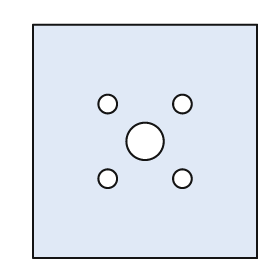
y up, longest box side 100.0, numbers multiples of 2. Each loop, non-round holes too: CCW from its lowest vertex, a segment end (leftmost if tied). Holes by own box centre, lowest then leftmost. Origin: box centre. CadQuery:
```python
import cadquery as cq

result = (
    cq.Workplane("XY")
    .moveTo(-48.0, -50.0)
    .lineTo(48.0, -50.0)
    .lineTo(48.0, 50.0)
    .lineTo(-48.0, 50.0)
    .close()
    .moveTo(-16.0, -16.0)
    .circle(4.0)
    .moveTo(16.0, -16.0)
    .circle(4.0)
    .moveTo(0.0, 0.0)
    .circle(8.0)
    .moveTo(-16.0, 16.0)
    .circle(4.0)
    .moveTo(16.0, 16.0)
    .circle(4.0)
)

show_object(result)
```